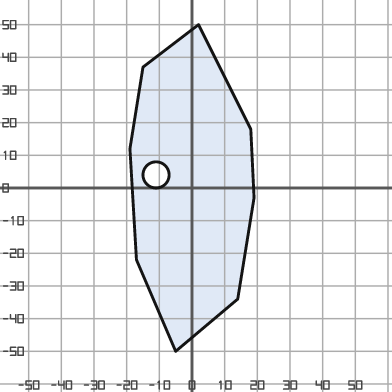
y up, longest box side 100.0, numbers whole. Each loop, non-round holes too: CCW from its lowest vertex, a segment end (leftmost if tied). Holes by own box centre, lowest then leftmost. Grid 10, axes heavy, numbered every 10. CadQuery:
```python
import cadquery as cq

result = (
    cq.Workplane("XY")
    .moveTo(-5.0, -50.0)
    .lineTo(14.0, -34.0)
    .lineTo(19.0, -3.0)
    .lineTo(18.0, 18.0)
    .lineTo(2.0, 50.0)
    .lineTo(-15.0, 37.0)
    .lineTo(-19.0, 12.0)
    .lineTo(-17.0, -22.0)
    .close()
    .moveTo(-11.0, 4.0)
    .circle(4.0)
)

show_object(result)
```